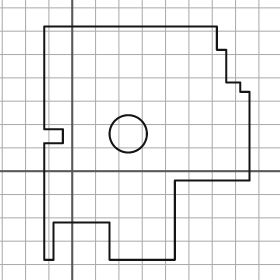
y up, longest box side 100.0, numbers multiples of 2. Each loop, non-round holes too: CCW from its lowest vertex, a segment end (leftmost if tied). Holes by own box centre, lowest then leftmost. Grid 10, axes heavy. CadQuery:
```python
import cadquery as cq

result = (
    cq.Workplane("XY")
    .moveTo(-12.0, -38.0)
    .lineTo(-8.0, -38.0)
    .lineTo(-8.0, -22.0)
    .lineTo(16.0, -22.0)
    .lineTo(16.0, -38.0)
    .lineTo(44.0, -38.0)
    .lineTo(44.0, -4.0)
    .lineTo(76.0, -4.0)
    .lineTo(76.0, 34.0)
    .lineTo(72.0, 34.0)
    .lineTo(72.0, 38.0)
    .lineTo(66.0, 38.0)
    .lineTo(66.0, 52.0)
    .lineTo(62.0, 52.0)
    .lineTo(62.0, 62.0)
    .lineTo(-12.0, 62.0)
    .lineTo(-12.0, 18.0)
    .lineTo(-4.0, 18.0)
    .lineTo(-4.0, 12.0)
    .lineTo(-12.0, 12.0)
    .close()
    .moveTo(24.0, 16.0)
    .circle(8.0)
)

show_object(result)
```